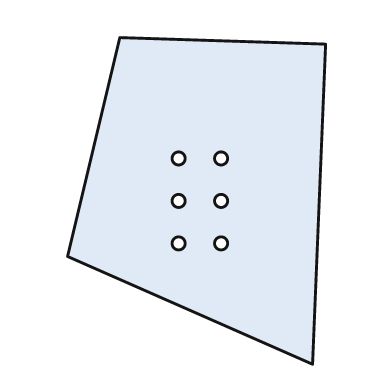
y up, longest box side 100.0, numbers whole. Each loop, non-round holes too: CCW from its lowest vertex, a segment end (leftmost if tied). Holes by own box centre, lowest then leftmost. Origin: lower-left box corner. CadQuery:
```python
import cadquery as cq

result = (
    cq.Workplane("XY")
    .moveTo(75.0, 0.0)
    .lineTo(79.0, 98.0)
    .lineTo(16.0, 100.0)
    .lineTo(0.0, 33.0)
    .close()
    .moveTo(34.0, 37.0)
    .circle(2.0)
    .moveTo(47.0, 37.0)
    .circle(2.0)
    .moveTo(34.0, 50.0)
    .circle(2.0)
    .moveTo(47.0, 50.0)
    .circle(2.0)
    .moveTo(34.0, 63.0)
    .circle(2.0)
    .moveTo(47.0, 63.0)
    .circle(2.0)
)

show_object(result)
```